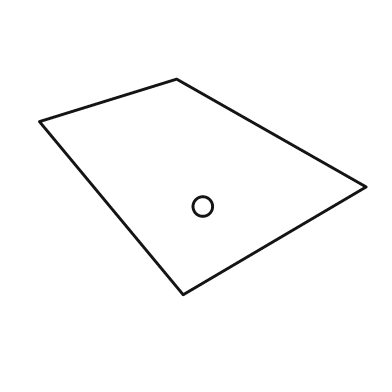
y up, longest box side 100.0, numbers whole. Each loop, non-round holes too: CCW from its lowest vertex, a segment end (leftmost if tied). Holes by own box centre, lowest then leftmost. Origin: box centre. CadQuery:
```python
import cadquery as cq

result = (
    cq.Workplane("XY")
    .moveTo(-6.0, -33.0)
    .lineTo(50.0, 0.0)
    .lineTo(-8.0, 33.0)
    .lineTo(-50.0, 20.0)
    .close()
    .moveTo(0.0, -6.0)
    .circle(3.0)
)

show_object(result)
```